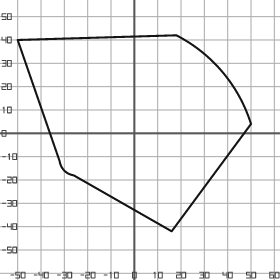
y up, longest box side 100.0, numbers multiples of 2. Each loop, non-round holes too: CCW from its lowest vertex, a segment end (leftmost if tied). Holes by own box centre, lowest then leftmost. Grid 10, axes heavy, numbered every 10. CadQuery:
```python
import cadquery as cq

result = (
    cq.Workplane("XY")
    .moveTo(16.0, -42.0)
    .lineTo(50.0, 4.0)
    .threePointArc((38.0, 26.0), (18.0, 42.0))
    .lineTo(-50.0, 40.0)
    .lineTo(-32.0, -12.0)
    .threePointArc((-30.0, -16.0), (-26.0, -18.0))
    .close()
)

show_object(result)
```